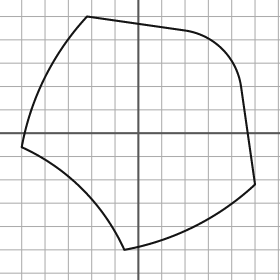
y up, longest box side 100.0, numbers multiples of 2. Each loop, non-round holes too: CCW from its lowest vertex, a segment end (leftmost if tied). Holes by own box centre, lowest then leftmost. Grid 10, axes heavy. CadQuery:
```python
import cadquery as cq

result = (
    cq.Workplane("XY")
    .moveTo(-6.0, -50.0)
    .threePointArc((24.0, -40.0), (50.0, -22.0))
    .lineTo(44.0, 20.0)
    .threePointArc((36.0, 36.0), (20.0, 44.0))
    .lineTo(-22.0, 50.0)
    .threePointArc((-40.0, 24.0), (-50.0, -6.0))
    .threePointArc((-24.0, -24.0), (-6.0, -50.0))
    .close()
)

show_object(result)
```